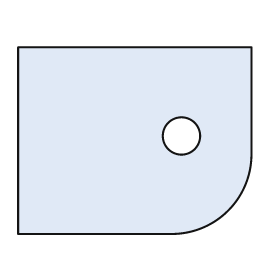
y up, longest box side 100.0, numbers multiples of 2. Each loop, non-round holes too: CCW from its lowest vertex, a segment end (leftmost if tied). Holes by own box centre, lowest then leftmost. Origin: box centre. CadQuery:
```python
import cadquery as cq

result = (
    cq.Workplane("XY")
    .moveTo(-50.0, -40.0)
    .lineTo(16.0, -40.0)
    .threePointArc((40.0, -30.0), (50.0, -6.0))
    .lineTo(50.0, 40.0)
    .lineTo(-50.0, 40.0)
    .close()
    .moveTo(20.0, 2.0)
    .circle(8.0)
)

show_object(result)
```